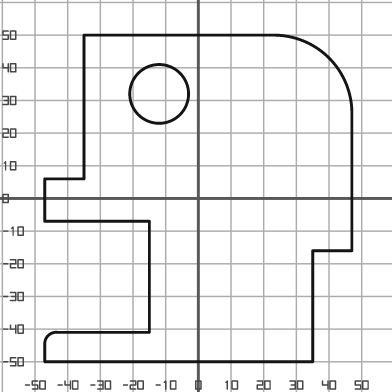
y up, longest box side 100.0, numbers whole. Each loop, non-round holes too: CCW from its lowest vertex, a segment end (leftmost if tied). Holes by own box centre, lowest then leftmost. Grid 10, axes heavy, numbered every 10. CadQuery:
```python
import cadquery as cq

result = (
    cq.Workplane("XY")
    .moveTo(-47.0, -50.0)
    .lineTo(35.0, -50.0)
    .lineTo(35.0, -16.0)
    .lineTo(47.0, -16.0)
    .lineTo(47.0, 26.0)
    .threePointArc((40.0, 43.0), (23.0, 50.0))
    .lineTo(-35.0, 50.0)
    .lineTo(-35.0, 6.0)
    .lineTo(-47.0, 6.0)
    .lineTo(-47.0, -7.0)
    .lineTo(-15.0, -7.0)
    .lineTo(-15.0, -41.0)
    .lineTo(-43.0, -41.0)
    .threePointArc((-46.0, -42.0), (-47.0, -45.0))
    .close()
    .moveTo(-12.0, 32.0)
    .circle(9.0)
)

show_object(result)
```